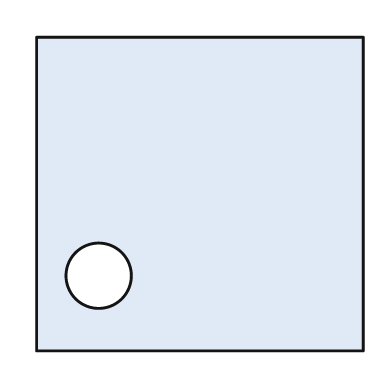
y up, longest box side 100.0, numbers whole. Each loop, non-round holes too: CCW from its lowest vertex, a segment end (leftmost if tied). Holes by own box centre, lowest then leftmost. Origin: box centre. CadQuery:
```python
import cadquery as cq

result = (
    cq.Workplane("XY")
    .moveTo(-50.0, -48.0)
    .lineTo(50.0, -48.0)
    .lineTo(50.0, 48.0)
    .lineTo(-50.0, 48.0)
    .close()
    .moveTo(-31.0, -25.0)
    .circle(10.0)
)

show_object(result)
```